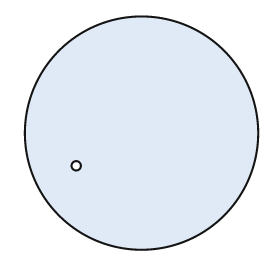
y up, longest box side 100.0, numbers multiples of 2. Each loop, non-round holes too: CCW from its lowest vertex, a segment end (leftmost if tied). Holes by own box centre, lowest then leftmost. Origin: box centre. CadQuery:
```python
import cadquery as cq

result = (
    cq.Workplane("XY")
    .moveTo(0.0, 0.0)
    .circle(50.0)
    .moveTo(-28.0, -14.0)
    .circle(2.0)
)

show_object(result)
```